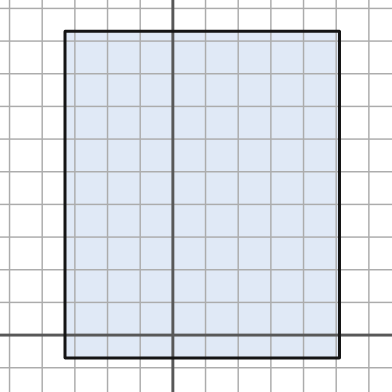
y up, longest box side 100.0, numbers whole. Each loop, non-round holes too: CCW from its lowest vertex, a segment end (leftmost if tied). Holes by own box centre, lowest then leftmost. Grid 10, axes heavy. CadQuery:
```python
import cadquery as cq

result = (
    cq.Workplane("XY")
    .moveTo(-33.0, -7.0)
    .lineTo(51.0, -7.0)
    .lineTo(51.0, 93.0)
    .lineTo(-33.0, 93.0)
    .close()
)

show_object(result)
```